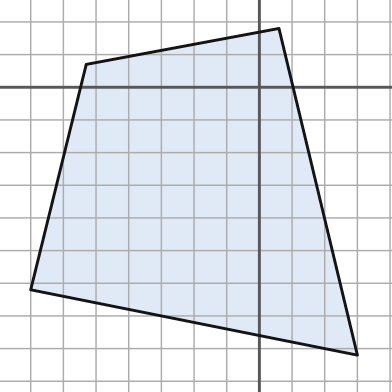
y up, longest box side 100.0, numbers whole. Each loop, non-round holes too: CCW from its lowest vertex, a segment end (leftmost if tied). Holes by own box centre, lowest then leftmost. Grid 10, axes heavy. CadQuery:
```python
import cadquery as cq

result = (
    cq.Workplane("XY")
    .moveTo(30.0, -82.0)
    .lineTo(6.0, 18.0)
    .lineTo(-53.0, 7.0)
    .lineTo(-70.0, -62.0)
    .close()
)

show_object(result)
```